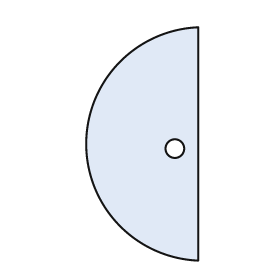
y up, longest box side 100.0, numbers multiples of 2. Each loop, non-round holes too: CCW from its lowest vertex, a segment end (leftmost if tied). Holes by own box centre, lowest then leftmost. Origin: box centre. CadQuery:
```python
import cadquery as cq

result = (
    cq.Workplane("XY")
    .moveTo(24.0, -50.0)
    .lineTo(24.0, 50.0)
    .threePointArc((-24.0, 0.0), (24.0, -50.0))
    .close()
    .moveTo(14.0, -2.0)
    .circle(4.0)
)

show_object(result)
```